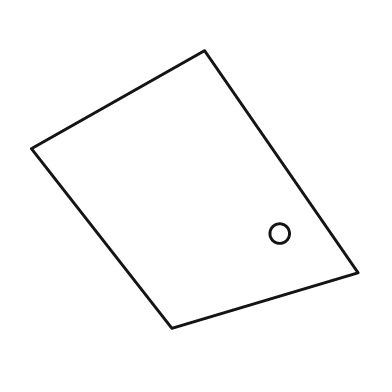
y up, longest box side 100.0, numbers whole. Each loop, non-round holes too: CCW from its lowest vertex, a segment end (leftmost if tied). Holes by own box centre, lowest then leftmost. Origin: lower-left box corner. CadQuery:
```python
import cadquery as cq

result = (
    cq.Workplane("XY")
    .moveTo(43.0, 0.0)
    .lineTo(100.0, 17.0)
    .lineTo(53.0, 85.0)
    .lineTo(0.0, 55.0)
    .close()
    .moveTo(76.0, 29.0)
    .circle(3.0)
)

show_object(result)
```